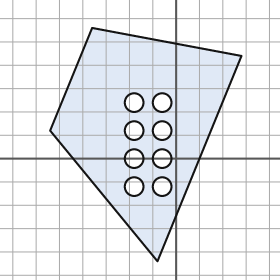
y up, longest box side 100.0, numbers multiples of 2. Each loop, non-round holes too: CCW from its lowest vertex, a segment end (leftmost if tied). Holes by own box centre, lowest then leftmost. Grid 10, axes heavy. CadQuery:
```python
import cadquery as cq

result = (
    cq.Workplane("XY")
    .moveTo(-8.0, -44.0)
    .lineTo(28.0, 44.0)
    .lineTo(-36.0, 56.0)
    .lineTo(-54.0, 12.0)
    .close()
    .moveTo(-18.0, -12.0)
    .circle(4.0)
    .moveTo(-6.0, -12.0)
    .circle(4.0)
    .moveTo(-18.0, 0.0)
    .circle(4.0)
    .moveTo(-6.0, 0.0)
    .circle(4.0)
    .moveTo(-18.0, 12.0)
    .circle(4.0)
    .moveTo(-6.0, 12.0)
    .circle(4.0)
    .moveTo(-18.0, 24.0)
    .circle(4.0)
    .moveTo(-6.0, 24.0)
    .circle(4.0)
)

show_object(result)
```